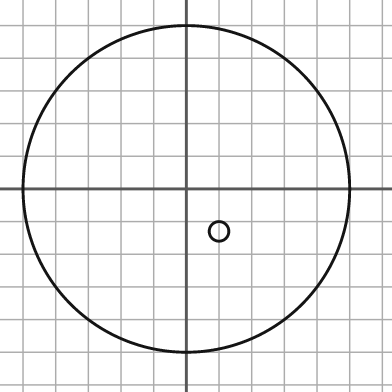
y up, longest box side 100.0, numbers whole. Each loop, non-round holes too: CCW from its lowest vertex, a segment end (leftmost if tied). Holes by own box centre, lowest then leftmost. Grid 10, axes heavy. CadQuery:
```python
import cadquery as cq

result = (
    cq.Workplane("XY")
    .moveTo(0.0, 0.0)
    .circle(50.0)
    .moveTo(10.0, -13.0)
    .circle(3.0)
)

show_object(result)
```